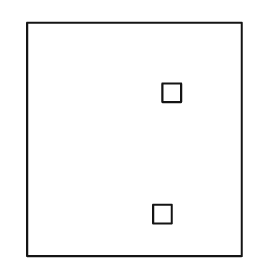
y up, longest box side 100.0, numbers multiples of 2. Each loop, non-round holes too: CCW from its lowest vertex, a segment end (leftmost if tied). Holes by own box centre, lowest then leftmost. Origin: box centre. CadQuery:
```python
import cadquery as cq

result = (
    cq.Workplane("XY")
    .moveTo(-46.0, -50.0)
    .lineTo(46.0, -50.0)
    .lineTo(46.0, 50.0)
    .lineTo(-46.0, 50.0)
    .close()
    .moveTo(8.0, -36.0)
    .lineTo(16.0, -36.0)
    .lineTo(16.0, -28.0)
    .lineTo(8.0, -28.0)
    .close()
    .moveTo(12.0, 16.0)
    .lineTo(20.0, 16.0)
    .lineTo(20.0, 24.0)
    .lineTo(12.0, 24.0)
    .close()
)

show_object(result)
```